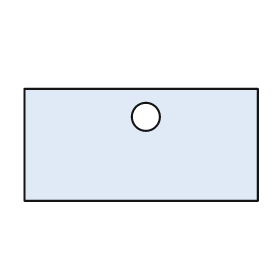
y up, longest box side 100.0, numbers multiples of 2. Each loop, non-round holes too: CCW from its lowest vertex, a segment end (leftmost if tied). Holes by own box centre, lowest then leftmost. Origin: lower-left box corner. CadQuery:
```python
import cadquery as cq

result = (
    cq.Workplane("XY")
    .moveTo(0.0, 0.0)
    .lineTo(100.0, 0.0)
    .lineTo(100.0, 48.0)
    .lineTo(0.0, 48.0)
    .close()
    .moveTo(52.0, 36.0)
    .circle(6.0)
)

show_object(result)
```